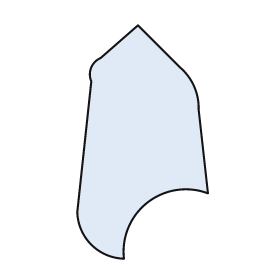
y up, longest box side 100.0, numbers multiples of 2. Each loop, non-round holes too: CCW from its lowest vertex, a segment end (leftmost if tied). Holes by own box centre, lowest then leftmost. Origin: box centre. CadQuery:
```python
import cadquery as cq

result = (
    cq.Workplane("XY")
    .moveTo(-8.0, -50.0)
    .threePointArc((2.0, -26.0), (28.0, -22.0))
    .lineTo(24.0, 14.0)
    .threePointArc((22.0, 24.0), (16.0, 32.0))
    .lineTo(-2.0, 50.0)
    .lineTo(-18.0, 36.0)
    .threePointArc((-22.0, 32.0), (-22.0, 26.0))
    .lineTo(-28.0, -30.0)
    .threePointArc((-22.0, -44.0), (-8.0, -50.0))
    .close()
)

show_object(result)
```